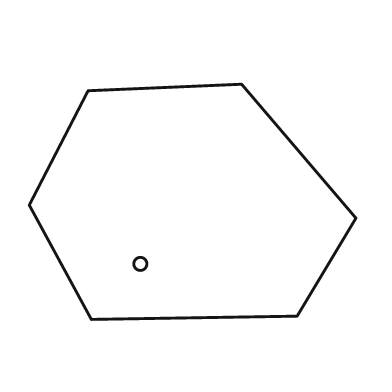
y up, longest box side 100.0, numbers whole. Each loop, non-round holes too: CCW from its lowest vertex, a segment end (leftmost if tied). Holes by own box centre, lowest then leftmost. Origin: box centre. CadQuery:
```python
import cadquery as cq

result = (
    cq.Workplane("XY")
    .moveTo(-31.0, -36.0)
    .lineTo(32.0, -35.0)
    .lineTo(50.0, -5.0)
    .lineTo(15.0, 36.0)
    .lineTo(-32.0, 34.0)
    .lineTo(-50.0, -1.0)
    .close()
    .moveTo(-16.0, -19.0)
    .circle(2.0)
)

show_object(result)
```